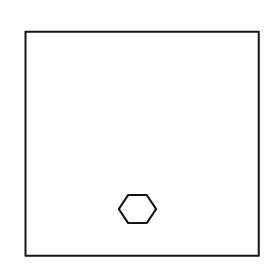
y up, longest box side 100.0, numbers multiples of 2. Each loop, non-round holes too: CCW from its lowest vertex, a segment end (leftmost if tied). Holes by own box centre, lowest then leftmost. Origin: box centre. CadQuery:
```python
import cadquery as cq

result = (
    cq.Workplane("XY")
    .moveTo(-50.0, -48.0)
    .lineTo(50.0, -48.0)
    .lineTo(50.0, 48.0)
    .lineTo(-50.0, 48.0)
    .close()
    .moveTo(-6.0, -34.0)
    .lineTo(2.0, -34.0)
    .lineTo(6.0, -28.0)
    .lineTo(2.0, -22.0)
    .lineTo(-6.0, -22.0)
    .lineTo(-10.0, -28.0)
    .close()
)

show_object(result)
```